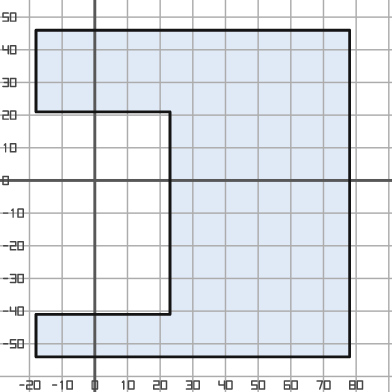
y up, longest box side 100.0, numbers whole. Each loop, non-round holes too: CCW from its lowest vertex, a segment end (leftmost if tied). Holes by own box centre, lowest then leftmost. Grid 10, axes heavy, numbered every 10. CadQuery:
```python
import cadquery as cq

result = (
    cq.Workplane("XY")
    .moveTo(-18.0, -54.0)
    .lineTo(78.0, -54.0)
    .lineTo(78.0, 46.0)
    .lineTo(-18.0, 46.0)
    .lineTo(-18.0, 21.0)
    .lineTo(23.0, 21.0)
    .lineTo(23.0, -41.0)
    .lineTo(-18.0, -41.0)
    .close()
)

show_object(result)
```